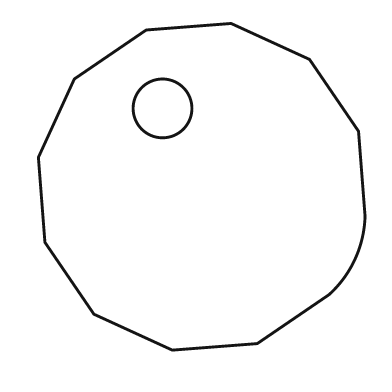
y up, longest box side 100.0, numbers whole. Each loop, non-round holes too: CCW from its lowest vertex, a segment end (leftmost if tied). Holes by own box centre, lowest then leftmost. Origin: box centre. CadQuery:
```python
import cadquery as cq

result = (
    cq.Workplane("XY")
    .moveTo(-9.0, -50.0)
    .lineTo(17.0, -48.0)
    .lineTo(39.0, -33.0)
    .threePointArc((47.0, -22.0), (50.0, -9.0))
    .lineTo(48.0, 17.0)
    .lineTo(33.0, 39.0)
    .lineTo(9.0, 50.0)
    .lineTo(-17.0, 48.0)
    .lineTo(-39.0, 33.0)
    .lineTo(-50.0, 9.0)
    .lineTo(-48.0, -17.0)
    .lineTo(-33.0, -39.0)
    .close()
    .moveTo(-12.0, 24.0)
    .circle(9.0)
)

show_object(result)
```